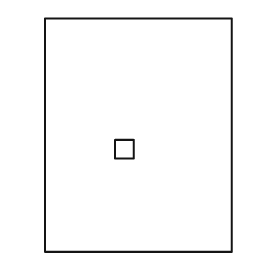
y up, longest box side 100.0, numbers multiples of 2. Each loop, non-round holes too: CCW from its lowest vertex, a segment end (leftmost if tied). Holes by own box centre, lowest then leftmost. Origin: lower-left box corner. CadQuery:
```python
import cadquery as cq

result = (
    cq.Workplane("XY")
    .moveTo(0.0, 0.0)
    .lineTo(80.0, 0.0)
    .lineTo(80.0, 100.0)
    .lineTo(0.0, 100.0)
    .close()
    .moveTo(30.0, 40.0)
    .lineTo(38.0, 40.0)
    .lineTo(38.0, 48.0)
    .lineTo(30.0, 48.0)
    .close()
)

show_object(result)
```